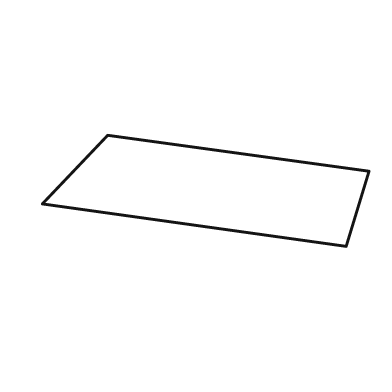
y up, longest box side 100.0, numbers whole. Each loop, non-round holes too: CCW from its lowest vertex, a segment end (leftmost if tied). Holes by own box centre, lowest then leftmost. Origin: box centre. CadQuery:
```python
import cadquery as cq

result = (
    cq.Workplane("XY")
    .moveTo(43.0, -17.0)
    .lineTo(50.0, 6.0)
    .lineTo(-30.0, 17.0)
    .lineTo(-50.0, -4.0)
    .close()
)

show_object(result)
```